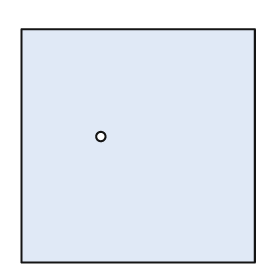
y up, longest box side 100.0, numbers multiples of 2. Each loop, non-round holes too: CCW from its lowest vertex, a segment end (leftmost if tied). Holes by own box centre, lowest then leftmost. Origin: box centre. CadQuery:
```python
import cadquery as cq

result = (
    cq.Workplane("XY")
    .moveTo(-50.0, -50.0)
    .lineTo(50.0, -50.0)
    .lineTo(50.0, 50.0)
    .lineTo(-50.0, 50.0)
    .close()
    .moveTo(-16.0, 4.0)
    .circle(2.0)
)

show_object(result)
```